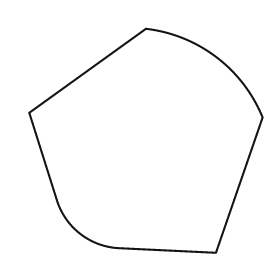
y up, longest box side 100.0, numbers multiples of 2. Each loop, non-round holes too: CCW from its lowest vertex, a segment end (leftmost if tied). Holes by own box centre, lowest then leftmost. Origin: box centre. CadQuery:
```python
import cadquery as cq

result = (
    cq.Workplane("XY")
    .moveTo(30.0, -48.0)
    .lineTo(50.0, 10.0)
    .threePointArc((30.0, 36.0), (0.0, 48.0))
    .lineTo(-50.0, 12.0)
    .lineTo(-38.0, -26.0)
    .threePointArc((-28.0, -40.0), (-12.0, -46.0))
    .close()
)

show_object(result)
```